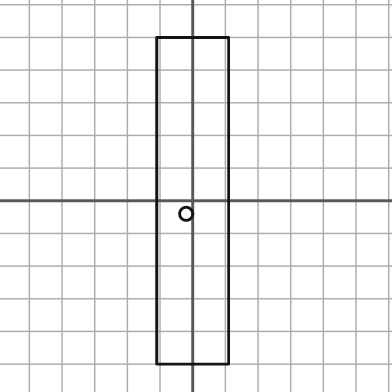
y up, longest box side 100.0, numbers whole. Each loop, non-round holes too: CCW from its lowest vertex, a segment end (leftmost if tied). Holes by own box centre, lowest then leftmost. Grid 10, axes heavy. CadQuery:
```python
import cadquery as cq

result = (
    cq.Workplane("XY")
    .moveTo(-11.0, -50.0)
    .lineTo(11.0, -50.0)
    .lineTo(11.0, 50.0)
    .lineTo(-11.0, 50.0)
    .close()
    .moveTo(-2.0, -4.0)
    .circle(2.0)
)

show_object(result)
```